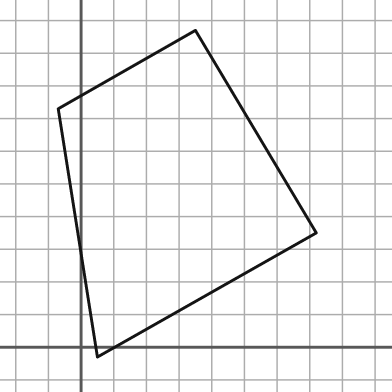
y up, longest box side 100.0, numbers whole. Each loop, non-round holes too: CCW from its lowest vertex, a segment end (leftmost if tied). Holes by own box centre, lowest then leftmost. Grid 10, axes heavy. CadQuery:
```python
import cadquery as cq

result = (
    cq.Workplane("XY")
    .moveTo(5.0, -3.0)
    .lineTo(72.0, 35.0)
    .lineTo(35.0, 97.0)
    .lineTo(-7.0, 73.0)
    .close()
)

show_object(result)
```